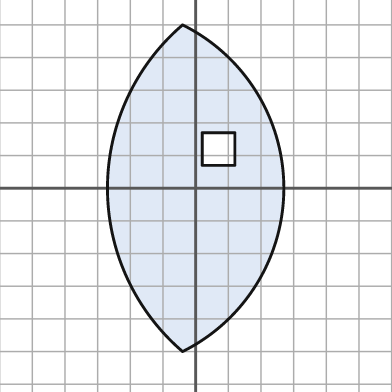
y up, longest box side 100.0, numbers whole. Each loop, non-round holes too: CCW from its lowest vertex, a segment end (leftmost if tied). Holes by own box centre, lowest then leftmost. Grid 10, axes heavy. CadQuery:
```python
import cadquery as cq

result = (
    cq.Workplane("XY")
    .moveTo(-4.0, -50.0)
    .threePointArc((27.0, 0.0), (-4.0, 50.0))
    .threePointArc((-27.0, 0.0), (-4.0, -50.0))
    .close()
    .moveTo(2.0, 7.0)
    .lineTo(12.0, 7.0)
    .lineTo(12.0, 17.0)
    .lineTo(2.0, 17.0)
    .close()
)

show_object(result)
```